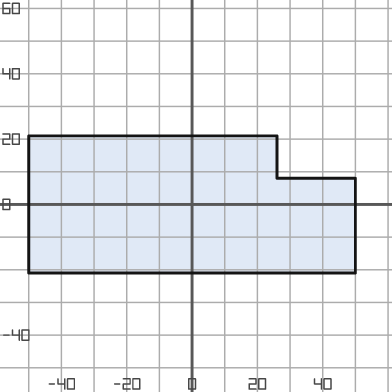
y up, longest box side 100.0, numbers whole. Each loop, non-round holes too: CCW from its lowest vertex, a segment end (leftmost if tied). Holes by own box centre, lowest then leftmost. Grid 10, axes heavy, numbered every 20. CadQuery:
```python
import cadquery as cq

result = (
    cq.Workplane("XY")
    .moveTo(-50.0, -21.0)
    .lineTo(50.0, -21.0)
    .lineTo(50.0, 8.0)
    .lineTo(26.0, 8.0)
    .lineTo(26.0, 21.0)
    .lineTo(-50.0, 21.0)
    .close()
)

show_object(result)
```